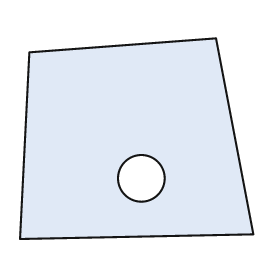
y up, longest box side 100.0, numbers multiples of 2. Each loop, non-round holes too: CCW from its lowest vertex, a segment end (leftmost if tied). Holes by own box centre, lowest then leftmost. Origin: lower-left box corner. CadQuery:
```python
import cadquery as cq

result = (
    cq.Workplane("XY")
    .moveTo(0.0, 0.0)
    .lineTo(100.0, 2.0)
    .lineTo(84.0, 86.0)
    .lineTo(4.0, 80.0)
    .close()
    .moveTo(52.0, 26.0)
    .circle(10.0)
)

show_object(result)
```